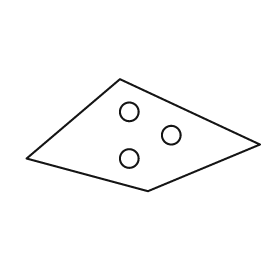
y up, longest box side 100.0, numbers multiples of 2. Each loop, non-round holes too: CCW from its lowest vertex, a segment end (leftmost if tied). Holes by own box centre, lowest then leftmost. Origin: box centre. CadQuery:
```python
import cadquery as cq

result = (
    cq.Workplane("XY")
    .moveTo(2.0, -24.0)
    .lineTo(50.0, -4.0)
    .lineTo(-10.0, 24.0)
    .lineTo(-50.0, -10.0)
    .close()
    .moveTo(-6.0, -10.0)
    .circle(4.0)
    .moveTo(12.0, 0.0)
    .circle(4.0)
    .moveTo(-6.0, 10.0)
    .circle(4.0)
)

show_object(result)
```